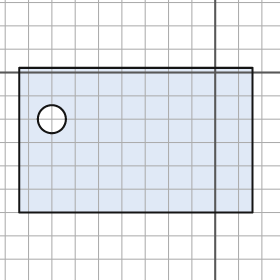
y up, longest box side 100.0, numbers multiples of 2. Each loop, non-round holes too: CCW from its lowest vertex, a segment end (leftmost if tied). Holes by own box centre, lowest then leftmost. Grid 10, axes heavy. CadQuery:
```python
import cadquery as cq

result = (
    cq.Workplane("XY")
    .moveTo(-84.0, -60.0)
    .lineTo(16.0, -60.0)
    .lineTo(16.0, 2.0)
    .lineTo(-84.0, 2.0)
    .close()
    .moveTo(-70.0, -20.0)
    .circle(6.0)
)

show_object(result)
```